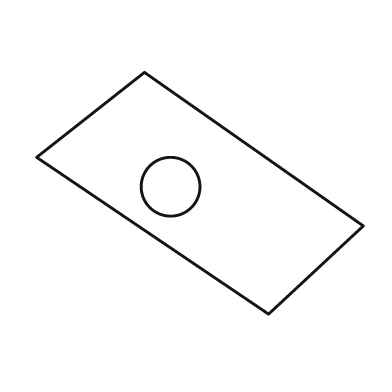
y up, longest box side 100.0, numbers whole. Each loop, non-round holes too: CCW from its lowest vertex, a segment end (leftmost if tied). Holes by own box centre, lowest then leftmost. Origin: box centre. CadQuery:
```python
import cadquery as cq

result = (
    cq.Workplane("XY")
    .moveTo(21.0, -37.0)
    .lineTo(50.0, -10.0)
    .lineTo(-17.0, 37.0)
    .lineTo(-50.0, 11.0)
    .close()
    .moveTo(-9.0, 2.0)
    .circle(9.0)
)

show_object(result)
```